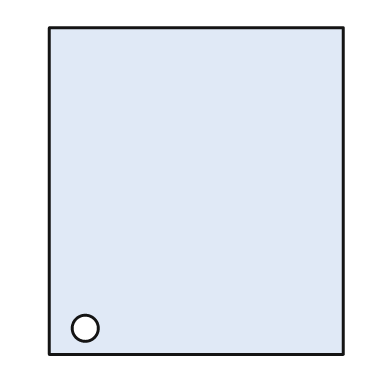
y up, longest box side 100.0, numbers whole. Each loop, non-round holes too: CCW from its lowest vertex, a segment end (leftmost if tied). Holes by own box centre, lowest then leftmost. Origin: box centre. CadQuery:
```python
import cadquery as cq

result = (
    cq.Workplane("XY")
    .moveTo(-45.0, -50.0)
    .lineTo(45.0, -50.0)
    .lineTo(45.0, 50.0)
    .lineTo(-45.0, 50.0)
    .close()
    .moveTo(-34.0, -42.0)
    .circle(4.0)
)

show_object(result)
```